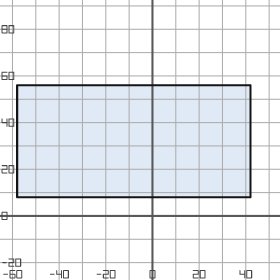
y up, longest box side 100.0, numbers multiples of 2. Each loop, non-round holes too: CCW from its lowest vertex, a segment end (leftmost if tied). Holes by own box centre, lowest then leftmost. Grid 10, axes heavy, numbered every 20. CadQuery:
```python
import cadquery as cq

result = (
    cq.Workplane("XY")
    .moveTo(-58.0, 8.0)
    .lineTo(42.0, 8.0)
    .lineTo(42.0, 56.0)
    .lineTo(-58.0, 56.0)
    .close()
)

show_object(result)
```